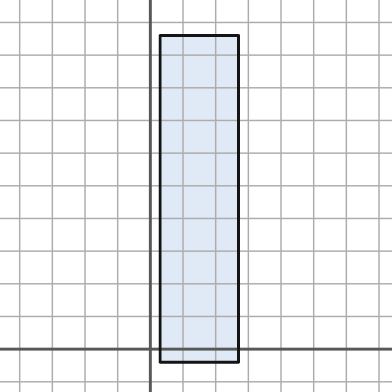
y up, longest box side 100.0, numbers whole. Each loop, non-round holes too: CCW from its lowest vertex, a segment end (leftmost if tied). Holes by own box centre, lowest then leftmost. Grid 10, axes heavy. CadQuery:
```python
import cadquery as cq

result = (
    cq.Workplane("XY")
    .moveTo(3.0, -4.0)
    .lineTo(27.0, -4.0)
    .lineTo(27.0, 96.0)
    .lineTo(3.0, 96.0)
    .close()
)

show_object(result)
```